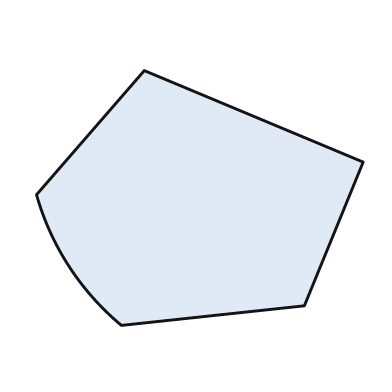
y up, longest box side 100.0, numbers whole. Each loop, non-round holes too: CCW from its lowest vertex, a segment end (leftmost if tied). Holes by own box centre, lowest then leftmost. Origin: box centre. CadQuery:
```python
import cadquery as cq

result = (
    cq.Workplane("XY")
    .moveTo(-24.0, -39.0)
    .lineTo(32.0, -33.0)
    .lineTo(50.0, 11.0)
    .lineTo(-17.0, 39.0)
    .lineTo(-50.0, 1.0)
    .threePointArc((-40.0, -21.0), (-24.0, -39.0))
    .close()
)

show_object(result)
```